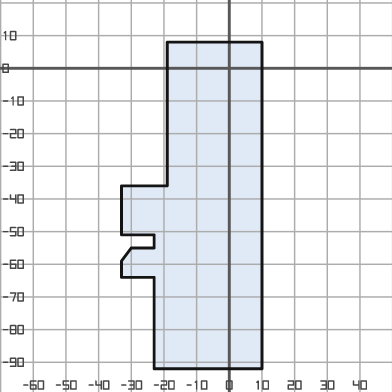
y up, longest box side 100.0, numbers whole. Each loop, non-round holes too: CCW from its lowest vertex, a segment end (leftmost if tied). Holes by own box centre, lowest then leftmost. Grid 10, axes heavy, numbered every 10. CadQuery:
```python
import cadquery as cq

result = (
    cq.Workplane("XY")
    .moveTo(-23.0, -92.0)
    .lineTo(10.0, -92.0)
    .lineTo(10.0, 8.0)
    .lineTo(-19.0, 8.0)
    .lineTo(-19.0, -36.0)
    .lineTo(-33.0, -36.0)
    .lineTo(-33.0, -51.0)
    .lineTo(-23.0, -51.0)
    .lineTo(-23.0, -55.0)
    .lineTo(-30.0, -55.0)
    .lineTo(-33.0, -59.0)
    .lineTo(-33.0, -64.0)
    .lineTo(-23.0, -64.0)
    .close()
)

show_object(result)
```